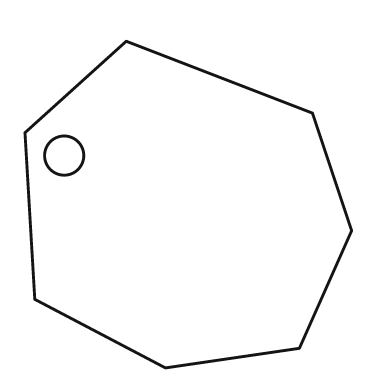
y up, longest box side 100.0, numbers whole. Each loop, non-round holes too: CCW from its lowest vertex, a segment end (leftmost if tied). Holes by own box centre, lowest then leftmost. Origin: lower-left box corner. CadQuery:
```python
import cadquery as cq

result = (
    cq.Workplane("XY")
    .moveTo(43.0, 0.0)
    .lineTo(84.0, 6.0)
    .lineTo(100.0, 42.0)
    .lineTo(88.0, 78.0)
    .lineTo(31.0, 100.0)
    .lineTo(0.0, 72.0)
    .lineTo(3.0, 21.0)
    .close()
    .moveTo(12.0, 65.0)
    .circle(6.0)
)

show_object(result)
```